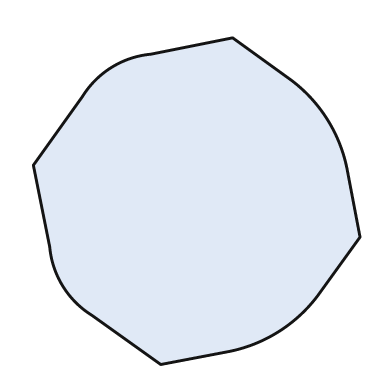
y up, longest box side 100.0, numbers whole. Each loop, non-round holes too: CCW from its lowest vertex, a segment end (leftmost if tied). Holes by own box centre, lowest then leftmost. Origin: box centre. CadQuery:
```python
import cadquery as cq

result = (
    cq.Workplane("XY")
    .moveTo(-11.0, -50.0)
    .lineTo(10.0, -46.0)
    .threePointArc((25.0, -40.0), (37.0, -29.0))
    .lineTo(50.0, -11.0)
    .lineTo(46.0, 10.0)
    .threePointArc((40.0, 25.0), (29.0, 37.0))
    .lineTo(11.0, 50.0)
    .lineTo(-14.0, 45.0)
    .threePointArc((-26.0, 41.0), (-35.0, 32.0))
    .lineTo(-50.0, 11.0)
    .lineTo(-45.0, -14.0)
    .threePointArc((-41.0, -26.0), (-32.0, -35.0))
    .close()
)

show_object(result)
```